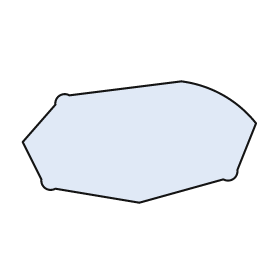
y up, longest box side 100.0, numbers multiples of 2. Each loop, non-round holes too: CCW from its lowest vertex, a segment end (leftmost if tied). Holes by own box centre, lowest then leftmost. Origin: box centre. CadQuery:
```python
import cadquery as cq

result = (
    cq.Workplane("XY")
    .moveTo(0.0, -26.0)
    .lineTo(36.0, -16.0)
    .threePointArc((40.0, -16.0), (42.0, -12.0))
    .lineTo(50.0, 8.0)
    .threePointArc((36.0, 20.0), (18.0, 26.0))
    .lineTo(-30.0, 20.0)
    .threePointArc((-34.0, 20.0), (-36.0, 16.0))
    .lineTo(-50.0, 0.0)
    .lineTo(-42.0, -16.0)
    .threePointArc((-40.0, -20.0), (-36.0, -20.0))
    .close()
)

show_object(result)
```